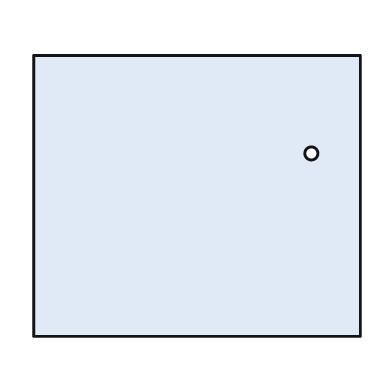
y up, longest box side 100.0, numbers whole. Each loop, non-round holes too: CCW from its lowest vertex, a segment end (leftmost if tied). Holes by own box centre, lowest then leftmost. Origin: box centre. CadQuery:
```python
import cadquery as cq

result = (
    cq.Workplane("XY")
    .moveTo(-50.0, -43.0)
    .lineTo(50.0, -43.0)
    .lineTo(50.0, 43.0)
    .lineTo(-50.0, 43.0)
    .close()
    .moveTo(35.0, 13.0)
    .circle(2.0)
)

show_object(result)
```